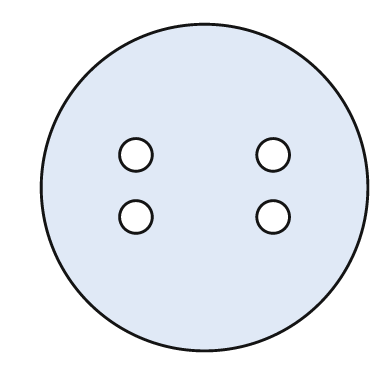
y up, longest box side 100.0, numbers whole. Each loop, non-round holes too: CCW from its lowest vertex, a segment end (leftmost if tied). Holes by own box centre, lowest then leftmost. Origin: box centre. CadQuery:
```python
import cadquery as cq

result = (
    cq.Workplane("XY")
    .moveTo(0.0, 0.0)
    .circle(50.0)
    .moveTo(-21.0, -9.0)
    .circle(5.0)
    .moveTo(21.0, -9.0)
    .circle(5.0)
    .moveTo(-21.0, 10.0)
    .circle(5.0)
    .moveTo(21.0, 10.0)
    .circle(5.0)
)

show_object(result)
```